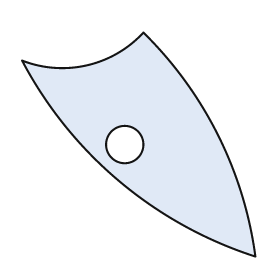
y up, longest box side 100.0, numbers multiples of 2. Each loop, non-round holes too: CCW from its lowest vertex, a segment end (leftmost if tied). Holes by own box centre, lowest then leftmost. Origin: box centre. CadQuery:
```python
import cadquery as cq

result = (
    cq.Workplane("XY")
    .moveTo(50.0, -48.0)
    .threePointArc((34.0, 4.0), (2.0, 48.0))
    .threePointArc((-22.0, 34.0), (-50.0, 36.0))
    .threePointArc((-8.0, -16.0), (50.0, -48.0))
    .close()
    .moveTo(-6.0, 0.0)
    .circle(8.0)
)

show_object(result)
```